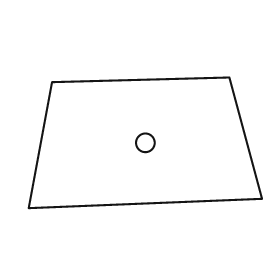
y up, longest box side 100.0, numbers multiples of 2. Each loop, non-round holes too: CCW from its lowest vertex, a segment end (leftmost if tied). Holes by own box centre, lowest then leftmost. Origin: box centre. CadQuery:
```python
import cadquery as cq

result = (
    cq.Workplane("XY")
    .moveTo(-50.0, -28.0)
    .lineTo(50.0, -24.0)
    .lineTo(36.0, 28.0)
    .lineTo(-40.0, 26.0)
    .close()
    .moveTo(0.0, 0.0)
    .circle(4.0)
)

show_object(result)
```